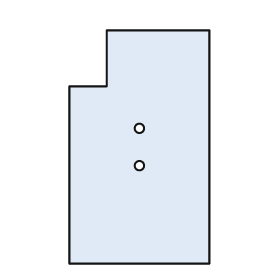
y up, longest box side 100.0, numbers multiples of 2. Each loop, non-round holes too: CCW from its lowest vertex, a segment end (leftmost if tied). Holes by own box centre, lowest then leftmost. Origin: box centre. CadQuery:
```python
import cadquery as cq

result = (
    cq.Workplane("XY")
    .moveTo(-30.0, -50.0)
    .lineTo(30.0, -50.0)
    .lineTo(30.0, 50.0)
    .lineTo(-14.0, 50.0)
    .lineTo(-14.0, 26.0)
    .lineTo(-30.0, 26.0)
    .close()
    .moveTo(0.0, -8.0)
    .circle(2.0)
    .moveTo(0.0, 8.0)
    .circle(2.0)
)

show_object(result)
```